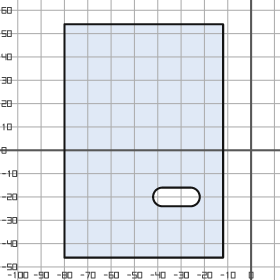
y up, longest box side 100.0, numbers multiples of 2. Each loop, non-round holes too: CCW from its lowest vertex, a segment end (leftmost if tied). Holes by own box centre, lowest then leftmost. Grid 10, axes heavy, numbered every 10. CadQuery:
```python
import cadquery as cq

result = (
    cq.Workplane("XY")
    .moveTo(-80.0, -46.0)
    .lineTo(-12.0, -46.0)
    .lineTo(-12.0, 54.0)
    .lineTo(-80.0, 54.0)
    .close()
    .moveTo(-38.0, -24.0)
    .lineTo(-26.0, -24.0)
    .threePointArc((-22.0, -20.0), (-26.0, -16.0))
    .lineTo(-38.0, -16.0)
    .threePointArc((-42.0, -20.0), (-38.0, -24.0))
    .close()
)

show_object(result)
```